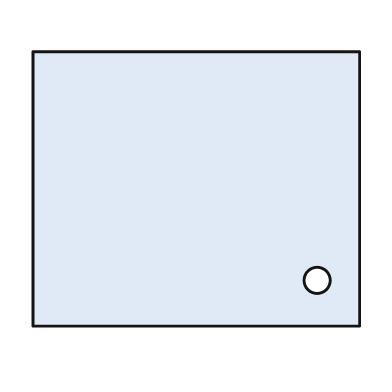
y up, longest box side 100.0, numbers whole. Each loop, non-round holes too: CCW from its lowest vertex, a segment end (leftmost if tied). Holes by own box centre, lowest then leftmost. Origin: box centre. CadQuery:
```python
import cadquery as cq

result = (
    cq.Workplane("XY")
    .moveTo(-50.0, -42.0)
    .lineTo(50.0, -42.0)
    .lineTo(50.0, 42.0)
    .lineTo(-50.0, 42.0)
    .close()
    .moveTo(37.0, -28.0)
    .circle(4.0)
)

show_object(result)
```